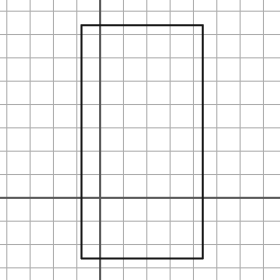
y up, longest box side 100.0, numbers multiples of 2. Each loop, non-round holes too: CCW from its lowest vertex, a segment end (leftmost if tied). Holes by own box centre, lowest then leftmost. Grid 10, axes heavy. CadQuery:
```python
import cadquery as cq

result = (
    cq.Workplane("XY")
    .moveTo(-8.0, -26.0)
    .lineTo(44.0, -26.0)
    .lineTo(44.0, 74.0)
    .lineTo(-8.0, 74.0)
    .close()
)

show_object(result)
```